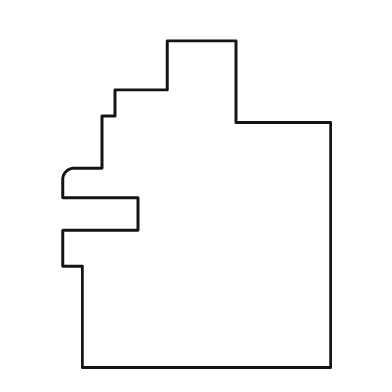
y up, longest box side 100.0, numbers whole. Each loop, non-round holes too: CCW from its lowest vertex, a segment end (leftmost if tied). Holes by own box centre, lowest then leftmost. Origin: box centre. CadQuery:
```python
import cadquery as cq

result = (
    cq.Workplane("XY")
    .moveTo(-35.0, -50.0)
    .lineTo(41.0, -50.0)
    .lineTo(41.0, 25.0)
    .lineTo(12.0, 25.0)
    .lineTo(12.0, 50.0)
    .lineTo(-9.0, 50.0)
    .lineTo(-9.0, 35.0)
    .lineTo(-25.0, 35.0)
    .lineTo(-25.0, 27.0)
    .lineTo(-29.0, 27.0)
    .lineTo(-29.0, 11.0)
    .lineTo(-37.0, 11.0)
    .threePointArc((-40.0, 10.0), (-41.0, 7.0))
    .lineTo(-41.0, 2.0)
    .lineTo(-18.0, 2.0)
    .lineTo(-18.0, -8.0)
    .lineTo(-41.0, -8.0)
    .lineTo(-41.0, -19.0)
    .lineTo(-35.0, -19.0)
    .close()
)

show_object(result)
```